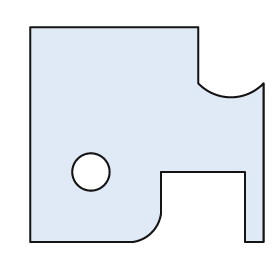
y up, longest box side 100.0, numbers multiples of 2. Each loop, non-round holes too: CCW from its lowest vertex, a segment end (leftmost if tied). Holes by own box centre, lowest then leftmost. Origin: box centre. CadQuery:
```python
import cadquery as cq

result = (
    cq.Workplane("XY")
    .moveTo(-50.0, -46.0)
    .lineTo(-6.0, -46.0)
    .threePointArc((2.0, -42.0), (6.0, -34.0))
    .lineTo(6.0, -16.0)
    .lineTo(42.0, -16.0)
    .lineTo(42.0, -46.0)
    .lineTo(50.0, -46.0)
    .lineTo(50.0, 22.0)
    .threePointArc((36.0, 16.0), (22.0, 22.0))
    .lineTo(22.0, 46.0)
    .lineTo(-50.0, 46.0)
    .close()
    .moveTo(-24.0, -16.0)
    .circle(8.0)
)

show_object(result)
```